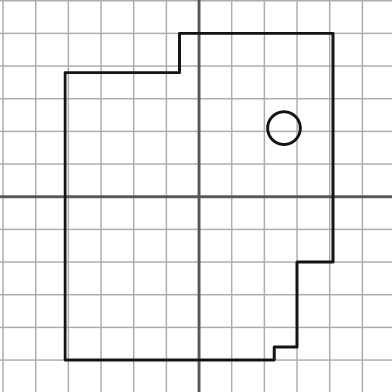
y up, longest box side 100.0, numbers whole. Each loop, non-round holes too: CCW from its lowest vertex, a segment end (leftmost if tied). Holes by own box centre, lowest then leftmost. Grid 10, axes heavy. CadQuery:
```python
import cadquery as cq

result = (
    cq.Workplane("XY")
    .moveTo(-41.0, -50.0)
    .lineTo(23.0, -50.0)
    .lineTo(23.0, -46.0)
    .lineTo(30.0, -46.0)
    .lineTo(30.0, -20.0)
    .lineTo(41.0, -20.0)
    .lineTo(41.0, 50.0)
    .lineTo(-6.0, 50.0)
    .lineTo(-6.0, 38.0)
    .lineTo(-41.0, 38.0)
    .close()
    .moveTo(26.0, 21.0)
    .circle(5.0)
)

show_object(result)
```